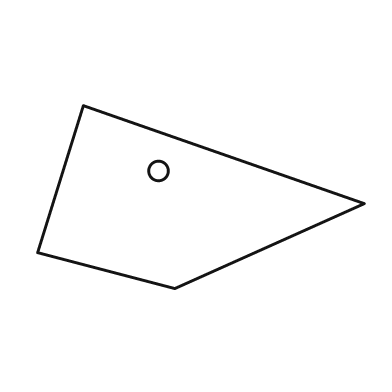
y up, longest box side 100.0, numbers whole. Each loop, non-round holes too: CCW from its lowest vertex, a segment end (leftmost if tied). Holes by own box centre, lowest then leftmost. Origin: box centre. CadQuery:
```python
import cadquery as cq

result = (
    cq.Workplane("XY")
    .moveTo(-8.0, -28.0)
    .lineTo(50.0, -2.0)
    .lineTo(-36.0, 28.0)
    .lineTo(-50.0, -17.0)
    .close()
    .moveTo(-13.0, 8.0)
    .circle(3.0)
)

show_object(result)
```